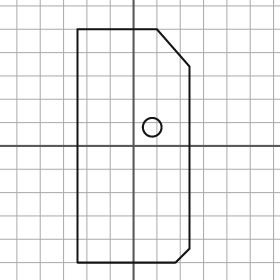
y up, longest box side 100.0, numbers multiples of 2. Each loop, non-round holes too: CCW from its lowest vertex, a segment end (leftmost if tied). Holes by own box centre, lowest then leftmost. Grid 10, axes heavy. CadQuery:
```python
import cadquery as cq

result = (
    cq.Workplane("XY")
    .moveTo(-24.0, -50.0)
    .lineTo(18.0, -50.0)
    .lineTo(24.0, -44.0)
    .lineTo(24.0, 34.0)
    .lineTo(10.0, 50.0)
    .lineTo(-24.0, 50.0)
    .close()
    .moveTo(8.0, 8.0)
    .circle(4.0)
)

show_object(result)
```